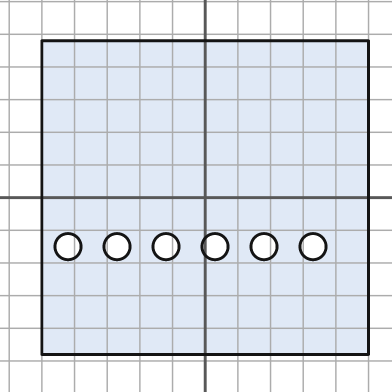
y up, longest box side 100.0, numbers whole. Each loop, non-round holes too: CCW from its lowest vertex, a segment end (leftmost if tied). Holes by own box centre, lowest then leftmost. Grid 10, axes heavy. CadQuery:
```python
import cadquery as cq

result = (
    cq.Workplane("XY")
    .moveTo(-50.0, -48.0)
    .lineTo(50.0, -48.0)
    .lineTo(50.0, 48.0)
    .lineTo(-50.0, 48.0)
    .close()
    .moveTo(-42.0, -15.0)
    .circle(4.0)
    .moveTo(-27.0, -15.0)
    .circle(4.0)
    .moveTo(-12.0, -15.0)
    .circle(4.0)
    .moveTo(3.0, -15.0)
    .circle(4.0)
    .moveTo(18.0, -15.0)
    .circle(4.0)
    .moveTo(33.0, -15.0)
    .circle(4.0)
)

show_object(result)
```